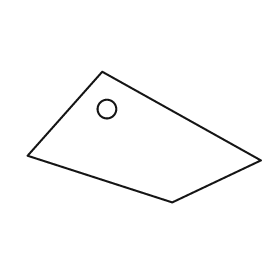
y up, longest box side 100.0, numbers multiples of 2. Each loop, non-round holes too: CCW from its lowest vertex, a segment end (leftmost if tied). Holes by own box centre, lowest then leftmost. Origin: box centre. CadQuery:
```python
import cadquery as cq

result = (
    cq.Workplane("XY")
    .moveTo(12.0, -28.0)
    .lineTo(50.0, -10.0)
    .lineTo(-18.0, 28.0)
    .lineTo(-50.0, -8.0)
    .close()
    .moveTo(-16.0, 12.0)
    .circle(4.0)
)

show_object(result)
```